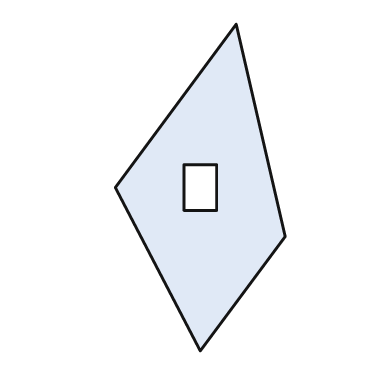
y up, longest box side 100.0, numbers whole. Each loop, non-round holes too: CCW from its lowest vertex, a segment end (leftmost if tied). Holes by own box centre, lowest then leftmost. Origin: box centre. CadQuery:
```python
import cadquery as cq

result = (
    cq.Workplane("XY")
    .moveTo(0.0, -50.0)
    .lineTo(26.0, -15.0)
    .lineTo(11.0, 50.0)
    .lineTo(-26.0, 0.0)
    .close()
    .moveTo(-5.0, -7.0)
    .lineTo(5.0, -7.0)
    .lineTo(5.0, 7.0)
    .lineTo(-5.0, 7.0)
    .close()
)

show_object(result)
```